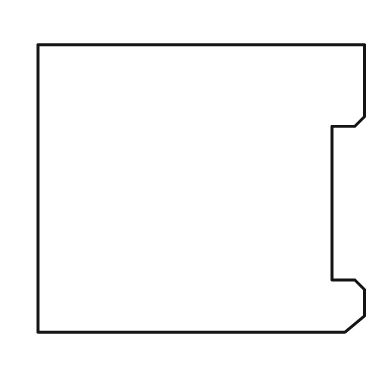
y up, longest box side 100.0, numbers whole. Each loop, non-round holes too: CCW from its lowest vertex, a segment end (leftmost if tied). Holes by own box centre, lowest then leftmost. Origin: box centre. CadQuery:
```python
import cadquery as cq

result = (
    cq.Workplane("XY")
    .moveTo(-50.0, -44.0)
    .lineTo(44.0, -44.0)
    .lineTo(50.0, -39.0)
    .lineTo(50.0, -31.0)
    .lineTo(47.0, -28.0)
    .lineTo(40.0, -28.0)
    .lineTo(40.0, 19.0)
    .lineTo(47.0, 19.0)
    .lineTo(50.0, 22.0)
    .lineTo(50.0, 44.0)
    .lineTo(-50.0, 44.0)
    .close()
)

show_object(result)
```